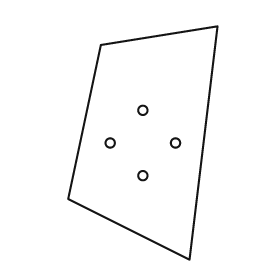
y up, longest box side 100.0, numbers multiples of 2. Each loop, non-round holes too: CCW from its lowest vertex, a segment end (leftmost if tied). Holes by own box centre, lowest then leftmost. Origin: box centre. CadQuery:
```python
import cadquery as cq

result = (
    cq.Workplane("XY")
    .moveTo(20.0, -50.0)
    .lineTo(32.0, 50.0)
    .lineTo(-18.0, 42.0)
    .lineTo(-32.0, -24.0)
    .close()
    .moveTo(0.0, -14.0)
    .circle(2.0)
    .moveTo(-14.0, 0.0)
    .circle(2.0)
    .moveTo(14.0, 0.0)
    .circle(2.0)
    .moveTo(0.0, 14.0)
    .circle(2.0)
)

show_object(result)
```